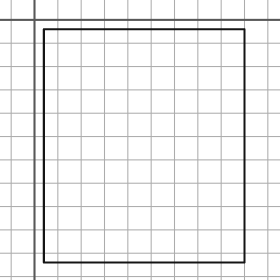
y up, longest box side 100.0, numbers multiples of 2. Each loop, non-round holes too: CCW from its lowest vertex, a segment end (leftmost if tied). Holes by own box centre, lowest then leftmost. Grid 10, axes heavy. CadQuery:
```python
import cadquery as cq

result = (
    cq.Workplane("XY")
    .moveTo(4.0, -104.0)
    .lineTo(90.0, -104.0)
    .lineTo(90.0, -4.0)
    .lineTo(4.0, -4.0)
    .close()
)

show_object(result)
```